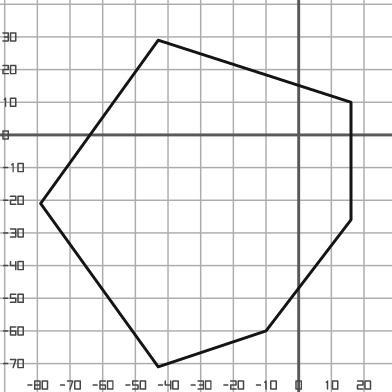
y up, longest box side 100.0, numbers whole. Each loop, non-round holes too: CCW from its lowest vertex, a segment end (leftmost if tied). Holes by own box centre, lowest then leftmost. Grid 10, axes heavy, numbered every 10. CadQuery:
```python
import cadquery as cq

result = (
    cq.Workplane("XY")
    .moveTo(-43.0, -71.0)
    .lineTo(-10.0, -60.0)
    .lineTo(16.0, -26.0)
    .lineTo(16.0, 10.0)
    .lineTo(-43.0, 29.0)
    .lineTo(-79.0, -21.0)
    .close()
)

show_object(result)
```